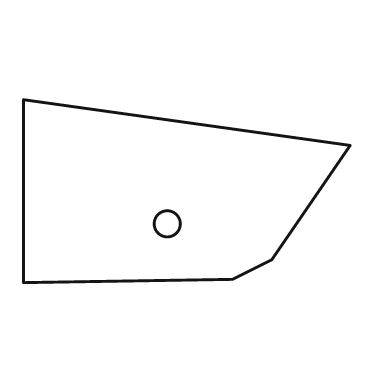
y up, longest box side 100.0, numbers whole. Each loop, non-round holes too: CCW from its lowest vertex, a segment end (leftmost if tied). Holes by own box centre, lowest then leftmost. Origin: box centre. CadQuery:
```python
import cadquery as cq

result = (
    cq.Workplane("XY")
    .moveTo(-50.0, -28.0)
    .lineTo(14.0, -27.0)
    .lineTo(26.0, -21.0)
    .lineTo(50.0, 14.0)
    .lineTo(-50.0, 28.0)
    .close()
    .moveTo(-6.0, -10.0)
    .circle(4.0)
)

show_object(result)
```